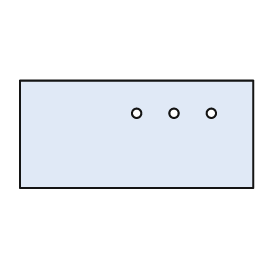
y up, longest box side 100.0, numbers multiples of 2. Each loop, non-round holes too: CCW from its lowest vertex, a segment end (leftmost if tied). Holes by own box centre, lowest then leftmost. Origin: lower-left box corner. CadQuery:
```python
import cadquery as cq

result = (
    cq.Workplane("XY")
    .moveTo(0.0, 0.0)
    .lineTo(100.0, 0.0)
    .lineTo(100.0, 46.0)
    .lineTo(0.0, 46.0)
    .close()
    .moveTo(50.0, 32.0)
    .circle(2.0)
    .moveTo(66.0, 32.0)
    .circle(2.0)
    .moveTo(82.0, 32.0)
    .circle(2.0)
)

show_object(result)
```